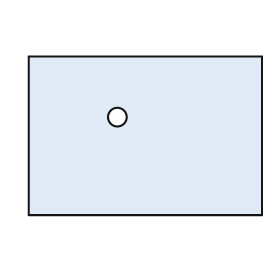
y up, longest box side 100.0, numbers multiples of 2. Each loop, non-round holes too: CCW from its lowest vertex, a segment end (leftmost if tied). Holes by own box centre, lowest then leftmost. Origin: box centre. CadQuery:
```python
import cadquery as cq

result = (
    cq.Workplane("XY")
    .moveTo(-50.0, -34.0)
    .lineTo(50.0, -34.0)
    .lineTo(50.0, 34.0)
    .lineTo(-50.0, 34.0)
    .close()
    .moveTo(-12.0, 8.0)
    .circle(4.0)
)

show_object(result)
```